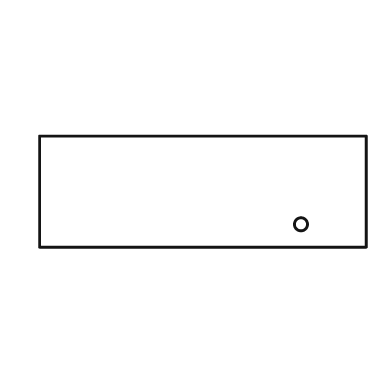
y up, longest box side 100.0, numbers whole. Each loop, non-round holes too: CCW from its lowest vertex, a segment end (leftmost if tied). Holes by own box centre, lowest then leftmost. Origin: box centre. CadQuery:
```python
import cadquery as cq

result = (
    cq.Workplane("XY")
    .moveTo(-50.0, -17.0)
    .lineTo(50.0, -17.0)
    .lineTo(50.0, 17.0)
    .lineTo(-50.0, 17.0)
    .close()
    .moveTo(30.0, -10.0)
    .circle(2.0)
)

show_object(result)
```